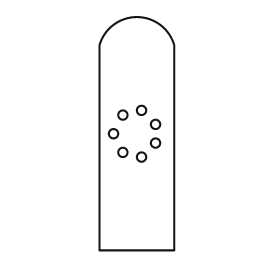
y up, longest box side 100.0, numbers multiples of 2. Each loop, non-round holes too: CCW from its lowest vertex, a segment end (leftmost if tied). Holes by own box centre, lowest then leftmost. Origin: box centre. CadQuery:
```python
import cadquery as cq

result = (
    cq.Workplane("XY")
    .moveTo(-16.0, -50.0)
    .lineTo(16.0, -50.0)
    .lineTo(16.0, 38.0)
    .threePointArc((0.0, 50.0), (-16.0, 38.0))
    .close()
    .moveTo(2.0, -10.0)
    .circle(2.0)
    .moveTo(-6.0, -8.0)
    .circle(2.0)
    .moveTo(8.0, -4.0)
    .circle(2.0)
    .moveTo(-10.0, 0.0)
    .circle(2.0)
    .moveTo(8.0, 4.0)
    .circle(2.0)
    .moveTo(-6.0, 8.0)
    .circle(2.0)
    .moveTo(2.0, 10.0)
    .circle(2.0)
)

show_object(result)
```